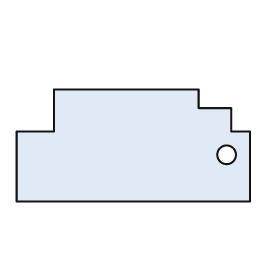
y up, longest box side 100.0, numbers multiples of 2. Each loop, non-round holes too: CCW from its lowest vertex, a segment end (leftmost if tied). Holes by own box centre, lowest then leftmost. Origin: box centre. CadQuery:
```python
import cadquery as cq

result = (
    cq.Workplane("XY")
    .moveTo(-50.0, -24.0)
    .lineTo(50.0, -24.0)
    .lineTo(50.0, 6.0)
    .lineTo(42.0, 6.0)
    .lineTo(42.0, 16.0)
    .lineTo(28.0, 16.0)
    .lineTo(28.0, 24.0)
    .lineTo(-34.0, 24.0)
    .lineTo(-34.0, 6.0)
    .lineTo(-50.0, 6.0)
    .close()
    .moveTo(40.0, -4.0)
    .circle(4.0)
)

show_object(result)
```